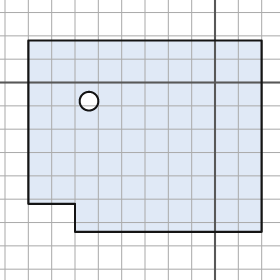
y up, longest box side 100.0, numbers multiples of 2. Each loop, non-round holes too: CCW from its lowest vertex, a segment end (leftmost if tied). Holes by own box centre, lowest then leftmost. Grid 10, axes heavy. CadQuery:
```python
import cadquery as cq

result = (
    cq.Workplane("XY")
    .moveTo(-60.0, -64.0)
    .lineTo(20.0, -64.0)
    .lineTo(20.0, 18.0)
    .lineTo(-80.0, 18.0)
    .lineTo(-80.0, -52.0)
    .lineTo(-60.0, -52.0)
    .close()
    .moveTo(-54.0, -8.0)
    .circle(4.0)
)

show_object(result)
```